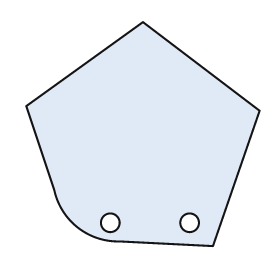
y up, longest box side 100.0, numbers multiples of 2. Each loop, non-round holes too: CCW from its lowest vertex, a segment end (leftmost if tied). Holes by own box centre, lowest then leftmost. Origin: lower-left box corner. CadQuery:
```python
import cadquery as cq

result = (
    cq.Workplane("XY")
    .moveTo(80.0, 0.0)
    .lineTo(100.0, 58.0)
    .lineTo(50.0, 96.0)
    .lineTo(0.0, 60.0)
    .lineTo(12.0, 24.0)
    .threePointArc((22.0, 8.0), (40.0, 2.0))
    .close()
    .moveTo(36.0, 10.0)
    .circle(4.0)
    .moveTo(70.0, 10.0)
    .circle(4.0)
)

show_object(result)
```